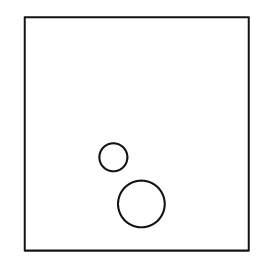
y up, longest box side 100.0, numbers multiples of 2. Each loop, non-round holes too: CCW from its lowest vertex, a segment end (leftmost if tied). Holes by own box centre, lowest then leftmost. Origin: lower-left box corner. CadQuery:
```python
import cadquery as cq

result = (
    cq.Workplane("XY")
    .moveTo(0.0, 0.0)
    .lineTo(96.0, 0.0)
    .lineTo(96.0, 100.0)
    .lineTo(0.0, 100.0)
    .close()
    .moveTo(50.0, 20.0)
    .circle(10.0)
    .moveTo(38.0, 40.0)
    .circle(6.0)
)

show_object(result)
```